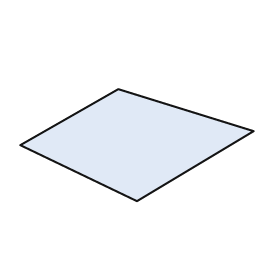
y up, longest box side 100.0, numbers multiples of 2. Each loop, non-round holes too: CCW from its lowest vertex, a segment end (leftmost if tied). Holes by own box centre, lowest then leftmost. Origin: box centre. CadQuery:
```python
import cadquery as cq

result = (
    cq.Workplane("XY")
    .moveTo(0.0, -24.0)
    .lineTo(50.0, 6.0)
    .lineTo(-8.0, 24.0)
    .lineTo(-50.0, 0.0)
    .close()
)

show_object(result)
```